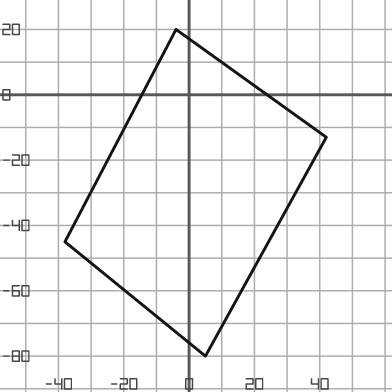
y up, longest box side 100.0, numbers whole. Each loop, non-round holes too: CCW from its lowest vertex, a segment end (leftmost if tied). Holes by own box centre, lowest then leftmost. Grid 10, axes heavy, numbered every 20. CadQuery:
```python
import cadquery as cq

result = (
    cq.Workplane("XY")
    .moveTo(5.0, -80.0)
    .lineTo(42.0, -13.0)
    .lineTo(-4.0, 20.0)
    .lineTo(-38.0, -45.0)
    .close()
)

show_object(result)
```